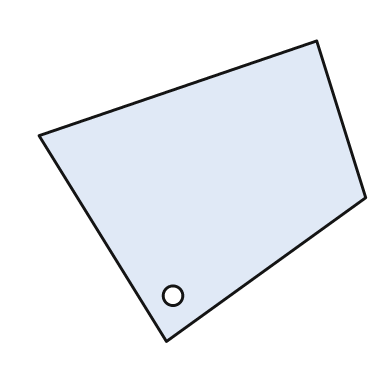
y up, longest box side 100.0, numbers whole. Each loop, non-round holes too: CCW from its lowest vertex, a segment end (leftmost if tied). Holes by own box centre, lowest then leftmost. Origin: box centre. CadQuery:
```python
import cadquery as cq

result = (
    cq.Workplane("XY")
    .moveTo(-11.0, -46.0)
    .lineTo(50.0, -2.0)
    .lineTo(35.0, 46.0)
    .lineTo(-50.0, 17.0)
    .close()
    .moveTo(-9.0, -32.0)
    .circle(3.0)
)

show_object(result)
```